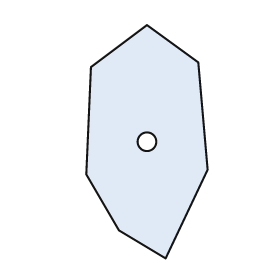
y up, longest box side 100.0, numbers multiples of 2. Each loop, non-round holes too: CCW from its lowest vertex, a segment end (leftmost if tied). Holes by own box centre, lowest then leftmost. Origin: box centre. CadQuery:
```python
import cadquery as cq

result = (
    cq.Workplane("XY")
    .moveTo(8.0, -50.0)
    .lineTo(26.0, -12.0)
    .lineTo(22.0, 34.0)
    .lineTo(0.0, 50.0)
    .lineTo(-24.0, 32.0)
    .lineTo(-26.0, -14.0)
    .lineTo(-12.0, -38.0)
    .close()
    .moveTo(0.0, 0.0)
    .circle(4.0)
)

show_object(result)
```